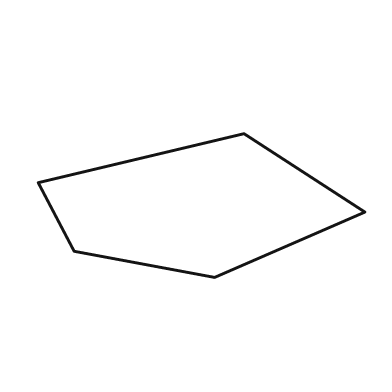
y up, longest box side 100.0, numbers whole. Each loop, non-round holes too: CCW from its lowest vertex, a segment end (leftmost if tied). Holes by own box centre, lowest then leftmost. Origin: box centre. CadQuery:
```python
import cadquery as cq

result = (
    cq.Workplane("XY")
    .moveTo(4.0, -22.0)
    .lineTo(50.0, -2.0)
    .lineTo(13.0, 22.0)
    .lineTo(-50.0, 7.0)
    .lineTo(-39.0, -14.0)
    .close()
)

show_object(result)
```